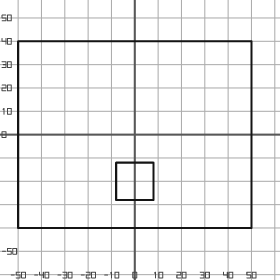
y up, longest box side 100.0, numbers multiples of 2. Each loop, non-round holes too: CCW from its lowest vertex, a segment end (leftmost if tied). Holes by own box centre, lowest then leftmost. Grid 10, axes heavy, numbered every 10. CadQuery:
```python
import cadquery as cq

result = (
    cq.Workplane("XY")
    .moveTo(-50.0, -40.0)
    .lineTo(50.0, -40.0)
    .lineTo(50.0, 40.0)
    .lineTo(-50.0, 40.0)
    .close()
    .moveTo(-8.0, -28.0)
    .lineTo(8.0, -28.0)
    .lineTo(8.0, -12.0)
    .lineTo(-8.0, -12.0)
    .close()
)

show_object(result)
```